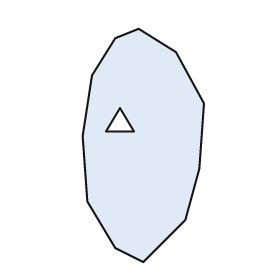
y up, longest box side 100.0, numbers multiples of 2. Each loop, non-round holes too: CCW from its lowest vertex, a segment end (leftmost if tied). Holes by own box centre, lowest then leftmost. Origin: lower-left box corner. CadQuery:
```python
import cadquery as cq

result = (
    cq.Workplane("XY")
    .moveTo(26.0, 0.0)
    .lineTo(44.0, 18.0)
    .lineTo(50.0, 40.0)
    .lineTo(52.0, 68.0)
    .lineTo(40.0, 90.0)
    .lineTo(24.0, 100.0)
    .lineTo(14.0, 96.0)
    .lineTo(4.0, 80.0)
    .lineTo(0.0, 54.0)
    .lineTo(2.0, 26.0)
    .lineTo(14.0, 6.0)
    .close()
    .moveTo(10.0, 56.0)
    .lineTo(22.0, 56.0)
    .lineTo(16.0, 66.0)
    .close()
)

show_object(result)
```